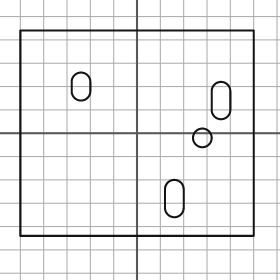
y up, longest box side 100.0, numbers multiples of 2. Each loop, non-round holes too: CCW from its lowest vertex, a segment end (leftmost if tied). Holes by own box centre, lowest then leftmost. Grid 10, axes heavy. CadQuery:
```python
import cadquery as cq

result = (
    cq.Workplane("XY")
    .moveTo(-50.0, -44.0)
    .lineTo(50.0, -44.0)
    .lineTo(50.0, 44.0)
    .lineTo(-50.0, 44.0)
    .close()
    .moveTo(12.0, -32.0)
    .threePointArc((16.0, -36.0), (20.0, -32.0))
    .lineTo(20.0, -24.0)
    .threePointArc((16.0, -20.0), (12.0, -24.0))
    .close()
    .moveTo(28.0, -2.0)
    .circle(4.0)
    .moveTo(32.0, 10.0)
    .threePointArc((36.0, 6.0), (40.0, 10.0))
    .lineTo(40.0, 18.0)
    .threePointArc((36.0, 22.0), (32.0, 18.0))
    .close()
    .moveTo(-28.0, 18.0)
    .threePointArc((-24.0, 14.0), (-20.0, 18.0))
    .lineTo(-20.0, 22.0)
    .threePointArc((-24.0, 26.0), (-28.0, 22.0))
    .close()
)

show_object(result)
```